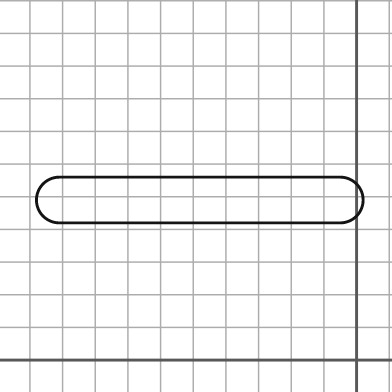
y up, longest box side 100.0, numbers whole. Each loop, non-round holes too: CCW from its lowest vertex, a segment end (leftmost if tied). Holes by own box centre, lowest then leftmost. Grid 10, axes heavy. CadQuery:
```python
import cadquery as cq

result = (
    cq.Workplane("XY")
    .moveTo(-91.0, 42.0)
    .lineTo(-5.0, 42.0)
    .threePointArc((2.0, 49.0), (-5.0, 56.0))
    .lineTo(-91.0, 56.0)
    .threePointArc((-98.0, 49.0), (-91.0, 42.0))
    .close()
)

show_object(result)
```